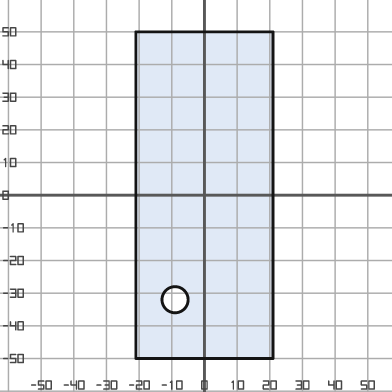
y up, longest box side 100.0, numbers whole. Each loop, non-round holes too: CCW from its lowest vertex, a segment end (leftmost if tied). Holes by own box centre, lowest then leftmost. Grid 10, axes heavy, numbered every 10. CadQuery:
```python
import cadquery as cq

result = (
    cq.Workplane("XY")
    .moveTo(-21.0, -50.0)
    .lineTo(21.0, -50.0)
    .lineTo(21.0, 50.0)
    .lineTo(-21.0, 50.0)
    .close()
    .moveTo(-9.0, -32.0)
    .circle(4.0)
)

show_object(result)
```